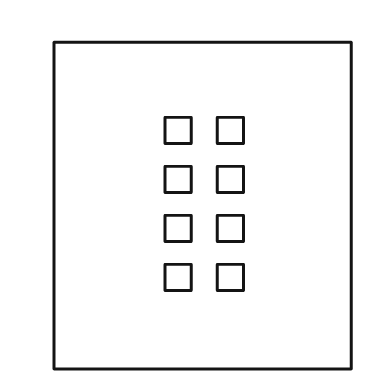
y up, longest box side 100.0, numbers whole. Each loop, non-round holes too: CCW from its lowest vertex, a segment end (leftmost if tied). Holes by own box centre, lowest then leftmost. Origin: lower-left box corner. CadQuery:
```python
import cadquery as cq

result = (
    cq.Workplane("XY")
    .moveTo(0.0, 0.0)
    .lineTo(91.0, 0.0)
    .lineTo(91.0, 100.0)
    .lineTo(0.0, 100.0)
    .close()
    .moveTo(34.0, 24.0)
    .lineTo(42.0, 24.0)
    .lineTo(42.0, 32.0)
    .lineTo(34.0, 32.0)
    .close()
    .moveTo(50.0, 24.0)
    .lineTo(58.0, 24.0)
    .lineTo(58.0, 32.0)
    .lineTo(50.0, 32.0)
    .close()
    .moveTo(34.0, 39.0)
    .lineTo(42.0, 39.0)
    .lineTo(42.0, 47.0)
    .lineTo(34.0, 47.0)
    .close()
    .moveTo(50.0, 39.0)
    .lineTo(58.0, 39.0)
    .lineTo(58.0, 47.0)
    .lineTo(50.0, 47.0)
    .close()
    .moveTo(34.0, 54.0)
    .lineTo(42.0, 54.0)
    .lineTo(42.0, 62.0)
    .lineTo(34.0, 62.0)
    .close()
    .moveTo(50.0, 54.0)
    .lineTo(58.0, 54.0)
    .lineTo(58.0, 62.0)
    .lineTo(50.0, 62.0)
    .close()
    .moveTo(34.0, 69.0)
    .lineTo(42.0, 69.0)
    .lineTo(42.0, 77.0)
    .lineTo(34.0, 77.0)
    .close()
    .moveTo(50.0, 69.0)
    .lineTo(58.0, 69.0)
    .lineTo(58.0, 77.0)
    .lineTo(50.0, 77.0)
    .close()
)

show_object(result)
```